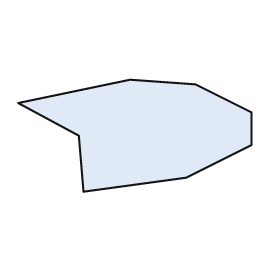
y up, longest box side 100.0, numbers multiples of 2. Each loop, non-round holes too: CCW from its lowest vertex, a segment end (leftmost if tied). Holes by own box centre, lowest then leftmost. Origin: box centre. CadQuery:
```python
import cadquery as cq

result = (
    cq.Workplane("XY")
    .moveTo(-22.0, -24.0)
    .lineTo(22.0, -18.0)
    .lineTo(50.0, -4.0)
    .lineTo(50.0, 10.0)
    .lineTo(26.0, 22.0)
    .lineTo(-2.0, 24.0)
    .lineTo(-50.0, 14.0)
    .lineTo(-24.0, 0.0)
    .close()
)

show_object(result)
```